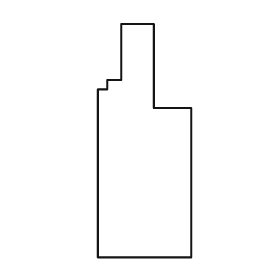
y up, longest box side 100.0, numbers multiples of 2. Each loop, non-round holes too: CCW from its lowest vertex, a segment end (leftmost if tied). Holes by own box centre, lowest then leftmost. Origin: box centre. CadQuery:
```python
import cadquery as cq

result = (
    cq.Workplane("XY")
    .moveTo(-20.0, -50.0)
    .lineTo(20.0, -50.0)
    .lineTo(20.0, 14.0)
    .lineTo(4.0, 14.0)
    .lineTo(4.0, 50.0)
    .lineTo(-10.0, 50.0)
    .lineTo(-10.0, 26.0)
    .lineTo(-16.0, 26.0)
    .lineTo(-16.0, 22.0)
    .lineTo(-20.0, 22.0)
    .close()
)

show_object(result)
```